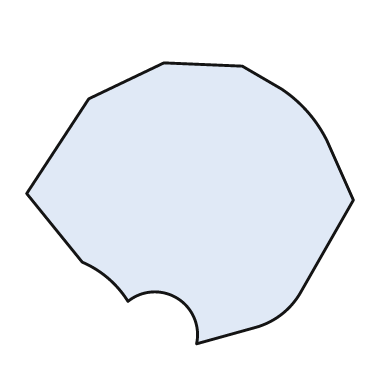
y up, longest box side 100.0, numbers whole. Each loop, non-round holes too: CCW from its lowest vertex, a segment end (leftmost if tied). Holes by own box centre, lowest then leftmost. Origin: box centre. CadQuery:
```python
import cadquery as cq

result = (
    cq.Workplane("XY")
    .moveTo(2.0, -43.0)
    .lineTo(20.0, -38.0)
    .threePointArc((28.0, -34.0), (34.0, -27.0))
    .lineTo(50.0, 1.0)
    .lineTo(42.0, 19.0)
    .threePointArc((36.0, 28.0), (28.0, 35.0))
    .lineTo(16.0, 42.0)
    .lineTo(-8.0, 43.0)
    .lineTo(-31.0, 32.0)
    .lineTo(-50.0, 3.0)
    .lineTo(-33.0, -18.0)
    .threePointArc((-25.0, -23.0), (-19.0, -30.0))
    .threePointArc((-4.0, -29.0), (2.0, -43.0))
    .close()
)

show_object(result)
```